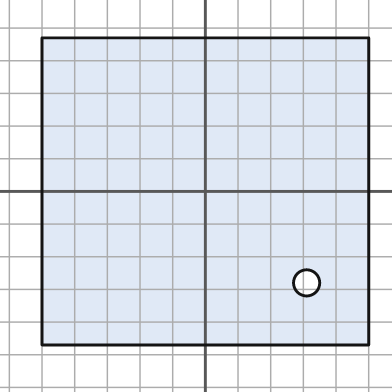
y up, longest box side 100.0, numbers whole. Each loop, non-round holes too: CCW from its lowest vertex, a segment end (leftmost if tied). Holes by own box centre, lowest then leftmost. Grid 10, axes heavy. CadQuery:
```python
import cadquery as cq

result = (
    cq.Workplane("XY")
    .moveTo(-50.0, -47.0)
    .lineTo(50.0, -47.0)
    .lineTo(50.0, 47.0)
    .lineTo(-50.0, 47.0)
    .close()
    .moveTo(31.0, -28.0)
    .circle(4.0)
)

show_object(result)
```